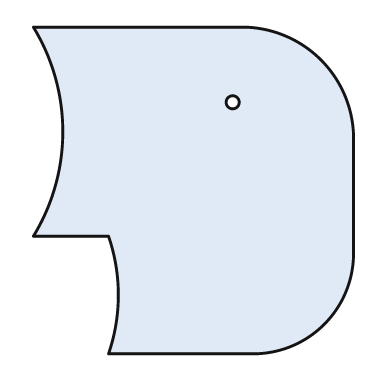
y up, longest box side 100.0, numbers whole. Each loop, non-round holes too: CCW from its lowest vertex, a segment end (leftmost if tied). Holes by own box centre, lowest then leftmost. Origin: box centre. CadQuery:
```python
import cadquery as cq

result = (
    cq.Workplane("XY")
    .moveTo(-26.0, -50.0)
    .lineTo(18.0, -50.0)
    .threePointArc((40.0, -41.0), (49.0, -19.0))
    .lineTo(49.0, 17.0)
    .threePointArc((39.0, 40.0), (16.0, 50.0))
    .lineTo(-49.0, 50.0)
    .threePointArc((-40.0, 18.0), (-49.0, -14.0))
    .lineTo(-26.0, -14.0)
    .threePointArc((-23.0, -32.0), (-26.0, -50.0))
    .close()
    .moveTo(12.0, 27.0)
    .circle(2.0)
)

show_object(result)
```